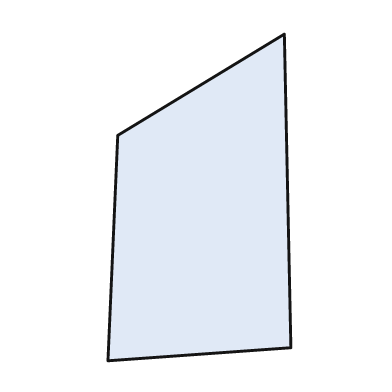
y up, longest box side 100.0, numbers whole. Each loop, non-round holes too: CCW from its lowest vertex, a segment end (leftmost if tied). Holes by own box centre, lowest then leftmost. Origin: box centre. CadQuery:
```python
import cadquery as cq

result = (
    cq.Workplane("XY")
    .moveTo(-28.0, -50.0)
    .lineTo(28.0, -46.0)
    .lineTo(26.0, 50.0)
    .lineTo(-25.0, 19.0)
    .close()
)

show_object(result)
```